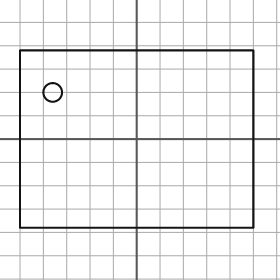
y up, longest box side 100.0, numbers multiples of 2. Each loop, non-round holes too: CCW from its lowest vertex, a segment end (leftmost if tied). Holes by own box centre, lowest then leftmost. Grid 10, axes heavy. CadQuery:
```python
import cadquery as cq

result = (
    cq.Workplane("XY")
    .moveTo(-50.0, -38.0)
    .lineTo(50.0, -38.0)
    .lineTo(50.0, 38.0)
    .lineTo(-50.0, 38.0)
    .close()
    .moveTo(-36.0, 20.0)
    .circle(4.0)
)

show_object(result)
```